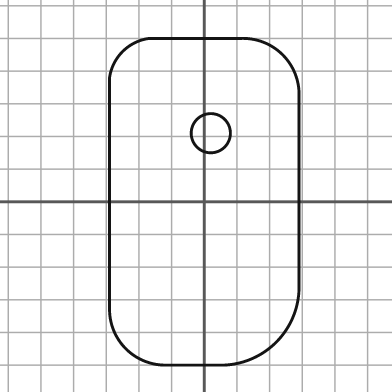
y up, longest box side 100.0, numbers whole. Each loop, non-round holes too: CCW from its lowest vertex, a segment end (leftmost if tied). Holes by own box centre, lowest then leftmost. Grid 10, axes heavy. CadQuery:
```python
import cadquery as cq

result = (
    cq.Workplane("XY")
    .moveTo(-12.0, -50.0)
    .lineTo(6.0, -50.0)
    .threePointArc((22.0, -43.0), (29.0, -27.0))
    .lineTo(29.0, 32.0)
    .threePointArc((24.0, 45.0), (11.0, 50.0))
    .lineTo(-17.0, 50.0)
    .threePointArc((-25.0, 46.0), (-29.0, 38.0))
    .lineTo(-29.0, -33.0)
    .threePointArc((-24.0, -45.0), (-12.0, -50.0))
    .close()
    .moveTo(2.0, 21.0)
    .circle(6.0)
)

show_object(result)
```